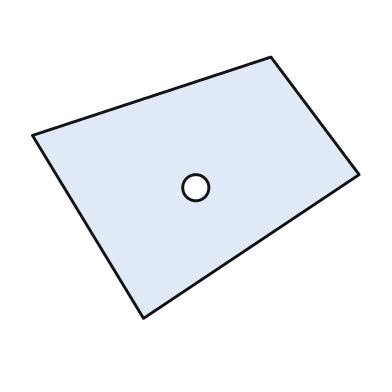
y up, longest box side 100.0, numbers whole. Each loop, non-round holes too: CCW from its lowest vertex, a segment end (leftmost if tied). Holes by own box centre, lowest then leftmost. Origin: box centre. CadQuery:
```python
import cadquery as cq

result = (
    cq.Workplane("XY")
    .moveTo(-16.0, -40.0)
    .lineTo(50.0, 4.0)
    .lineTo(23.0, 40.0)
    .lineTo(-50.0, 16.0)
    .close()
    .moveTo(0.0, 0.0)
    .circle(4.0)
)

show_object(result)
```